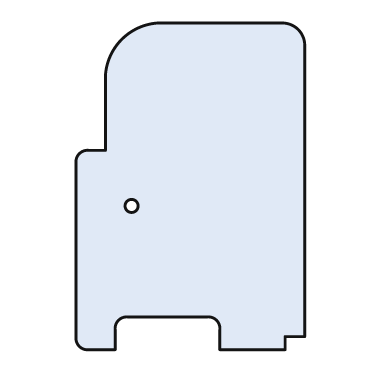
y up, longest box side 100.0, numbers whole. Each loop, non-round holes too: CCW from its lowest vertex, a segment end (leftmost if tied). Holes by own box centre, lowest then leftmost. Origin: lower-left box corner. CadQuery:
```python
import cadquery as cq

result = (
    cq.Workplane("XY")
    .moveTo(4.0, 0.0)
    .lineTo(12.0, 0.0)
    .lineTo(12.0, 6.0)
    .threePointArc((13.0, 9.0), (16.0, 10.0))
    .lineTo(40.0, 10.0)
    .threePointArc((43.0, 9.0), (44.0, 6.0))
    .lineTo(44.0, 0.0)
    .lineTo(64.0, 0.0)
    .lineTo(64.0, 4.0)
    .lineTo(70.0, 4.0)
    .lineTo(70.0, 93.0)
    .threePointArc((68.0, 98.0), (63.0, 100.0))
    .lineTo(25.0, 100.0)
    .threePointArc((14.0, 95.0), (9.0, 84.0))
    .lineTo(9.0, 61.0)
    .lineTo(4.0, 61.0)
    .threePointArc((1.0, 60.0), (0.0, 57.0))
    .lineTo(0.0, 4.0)
    .threePointArc((1.0, 1.0), (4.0, 0.0))
    .close()
    .moveTo(17.0, 44.0)
    .circle(2.0)
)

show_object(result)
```